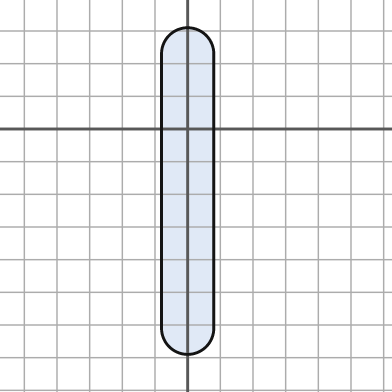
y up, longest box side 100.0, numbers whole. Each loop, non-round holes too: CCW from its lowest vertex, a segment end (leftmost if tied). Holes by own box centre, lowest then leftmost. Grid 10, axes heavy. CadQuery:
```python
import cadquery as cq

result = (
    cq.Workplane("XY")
    .moveTo(-8.0, -61.0)
    .threePointArc((0.0, -69.0), (8.0, -61.0))
    .lineTo(8.0, 23.0)
    .threePointArc((0.0, 31.0), (-8.0, 23.0))
    .close()
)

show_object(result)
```